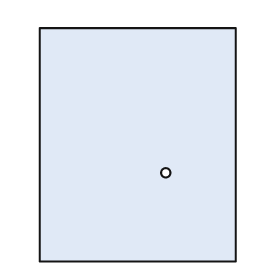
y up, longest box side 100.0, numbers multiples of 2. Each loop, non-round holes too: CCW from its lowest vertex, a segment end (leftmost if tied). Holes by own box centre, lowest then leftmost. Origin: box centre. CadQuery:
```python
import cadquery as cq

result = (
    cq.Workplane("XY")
    .moveTo(-42.0, -50.0)
    .lineTo(42.0, -50.0)
    .lineTo(42.0, 50.0)
    .lineTo(-42.0, 50.0)
    .close()
    .moveTo(12.0, -12.0)
    .circle(2.0)
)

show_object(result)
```